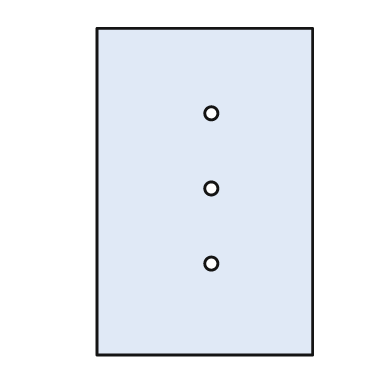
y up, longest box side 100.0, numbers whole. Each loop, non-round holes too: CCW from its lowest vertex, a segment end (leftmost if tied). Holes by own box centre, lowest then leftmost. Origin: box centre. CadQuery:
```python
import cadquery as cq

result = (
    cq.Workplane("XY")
    .moveTo(-33.0, -50.0)
    .lineTo(33.0, -50.0)
    .lineTo(33.0, 50.0)
    .lineTo(-33.0, 50.0)
    .close()
    .moveTo(2.0, -22.0)
    .circle(2.0)
    .moveTo(2.0, 1.0)
    .circle(2.0)
    .moveTo(2.0, 24.0)
    .circle(2.0)
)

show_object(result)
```